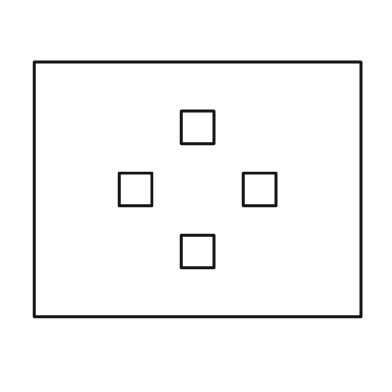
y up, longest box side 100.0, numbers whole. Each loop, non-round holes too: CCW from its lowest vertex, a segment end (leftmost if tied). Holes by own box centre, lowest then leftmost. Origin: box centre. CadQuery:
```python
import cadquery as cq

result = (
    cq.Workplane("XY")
    .moveTo(-50.0, -39.0)
    .lineTo(50.0, -39.0)
    .lineTo(50.0, 39.0)
    .lineTo(-50.0, 39.0)
    .close()
    .moveTo(-5.0, -24.0)
    .lineTo(5.0, -24.0)
    .lineTo(5.0, -14.0)
    .lineTo(-5.0, -14.0)
    .close()
    .moveTo(-24.0, -5.0)
    .lineTo(-14.0, -5.0)
    .lineTo(-14.0, 5.0)
    .lineTo(-24.0, 5.0)
    .close()
    .moveTo(14.0, -5.0)
    .lineTo(24.0, -5.0)
    .lineTo(24.0, 5.0)
    .lineTo(14.0, 5.0)
    .close()
    .moveTo(-5.0, 14.0)
    .lineTo(5.0, 14.0)
    .lineTo(5.0, 24.0)
    .lineTo(-5.0, 24.0)
    .close()
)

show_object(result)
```